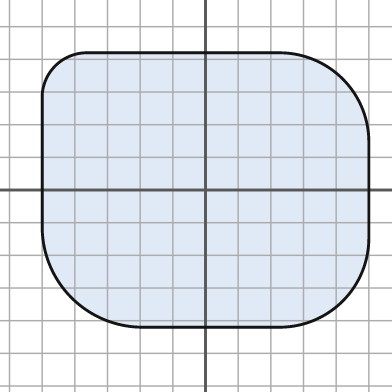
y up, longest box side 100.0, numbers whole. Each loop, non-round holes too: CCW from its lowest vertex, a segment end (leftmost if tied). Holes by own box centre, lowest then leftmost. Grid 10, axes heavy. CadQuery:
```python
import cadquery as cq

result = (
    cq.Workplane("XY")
    .moveTo(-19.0, -42.0)
    .lineTo(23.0, -42.0)
    .threePointArc((42.0, -34.0), (50.0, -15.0))
    .lineTo(50.0, 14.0)
    .threePointArc((42.0, 34.0), (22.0, 42.0))
    .lineTo(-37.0, 42.0)
    .threePointArc((-46.0, 38.0), (-50.0, 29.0))
    .lineTo(-50.0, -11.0)
    .threePointArc((-41.0, -33.0), (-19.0, -42.0))
    .close()
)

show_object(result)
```